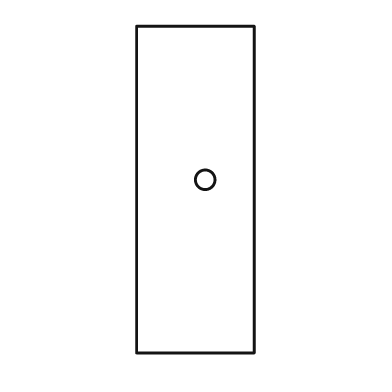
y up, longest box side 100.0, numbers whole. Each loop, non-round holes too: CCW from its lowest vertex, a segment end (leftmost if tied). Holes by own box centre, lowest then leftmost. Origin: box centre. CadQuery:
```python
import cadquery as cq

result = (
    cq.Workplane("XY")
    .moveTo(-18.0, -50.0)
    .lineTo(18.0, -50.0)
    .lineTo(18.0, 50.0)
    .lineTo(-18.0, 50.0)
    .close()
    .moveTo(3.0, 3.0)
    .circle(3.0)
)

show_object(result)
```